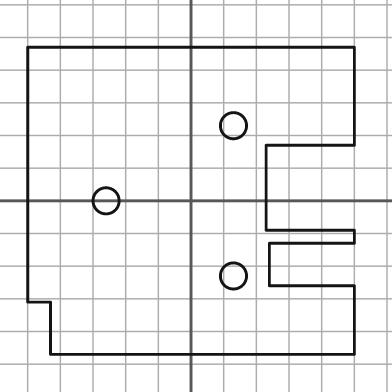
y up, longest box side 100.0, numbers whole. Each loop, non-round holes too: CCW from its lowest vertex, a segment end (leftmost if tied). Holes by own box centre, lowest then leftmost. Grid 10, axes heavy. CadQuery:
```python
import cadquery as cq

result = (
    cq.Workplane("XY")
    .moveTo(-43.0, -47.0)
    .lineTo(50.0, -47.0)
    .lineTo(50.0, -26.0)
    .lineTo(24.0, -26.0)
    .lineTo(24.0, -13.0)
    .lineTo(50.0, -13.0)
    .lineTo(50.0, -9.0)
    .lineTo(23.0, -9.0)
    .lineTo(23.0, 17.0)
    .lineTo(50.0, 17.0)
    .lineTo(50.0, 47.0)
    .lineTo(-50.0, 47.0)
    .lineTo(-50.0, -31.0)
    .lineTo(-43.0, -31.0)
    .close()
    .moveTo(13.0, -23.0)
    .circle(4.0)
    .moveTo(-26.0, 0.0)
    .circle(4.0)
    .moveTo(13.0, 23.0)
    .circle(4.0)
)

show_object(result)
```